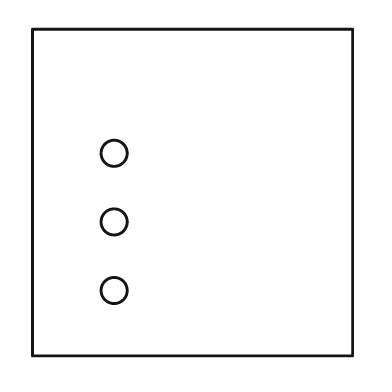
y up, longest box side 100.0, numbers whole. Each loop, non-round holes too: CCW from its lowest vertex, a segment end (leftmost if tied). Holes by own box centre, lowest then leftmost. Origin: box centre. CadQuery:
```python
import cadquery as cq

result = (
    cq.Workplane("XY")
    .moveTo(-49.0, -50.0)
    .lineTo(49.0, -50.0)
    .lineTo(49.0, 50.0)
    .lineTo(-49.0, 50.0)
    .close()
    .moveTo(-24.0, -30.0)
    .circle(4.0)
    .moveTo(-24.0, -9.0)
    .circle(4.0)
    .moveTo(-24.0, 12.0)
    .circle(4.0)
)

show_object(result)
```